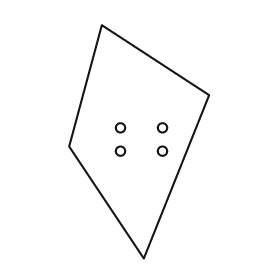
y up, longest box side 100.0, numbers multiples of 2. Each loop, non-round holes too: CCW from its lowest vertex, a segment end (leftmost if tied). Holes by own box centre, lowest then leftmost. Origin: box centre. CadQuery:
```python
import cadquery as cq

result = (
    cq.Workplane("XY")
    .moveTo(2.0, -50.0)
    .lineTo(30.0, 20.0)
    .lineTo(-16.0, 50.0)
    .lineTo(-30.0, -2.0)
    .close()
    .moveTo(-8.0, -4.0)
    .circle(2.0)
    .moveTo(10.0, -4.0)
    .circle(2.0)
    .moveTo(-8.0, 6.0)
    .circle(2.0)
    .moveTo(10.0, 6.0)
    .circle(2.0)
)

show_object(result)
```